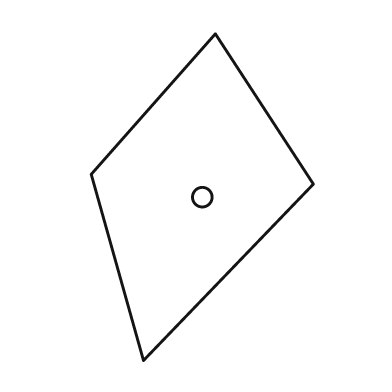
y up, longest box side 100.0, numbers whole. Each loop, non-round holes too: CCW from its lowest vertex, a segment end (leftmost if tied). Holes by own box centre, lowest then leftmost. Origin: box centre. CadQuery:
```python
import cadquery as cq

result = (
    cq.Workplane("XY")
    .moveTo(-18.0, -50.0)
    .lineTo(34.0, 4.0)
    .lineTo(4.0, 50.0)
    .lineTo(-34.0, 7.0)
    .close()
    .moveTo(0.0, 0.0)
    .circle(3.0)
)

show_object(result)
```